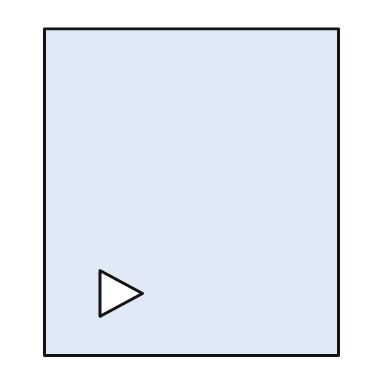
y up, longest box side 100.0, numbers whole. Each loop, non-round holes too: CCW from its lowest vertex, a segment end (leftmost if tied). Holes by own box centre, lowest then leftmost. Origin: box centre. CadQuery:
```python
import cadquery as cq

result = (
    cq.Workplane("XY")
    .moveTo(-45.0, -50.0)
    .lineTo(45.0, -50.0)
    .lineTo(45.0, 50.0)
    .lineTo(-45.0, 50.0)
    .close()
    .moveTo(-28.0, -38.0)
    .lineTo(-15.0, -31.0)
    .lineTo(-28.0, -24.0)
    .close()
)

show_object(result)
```